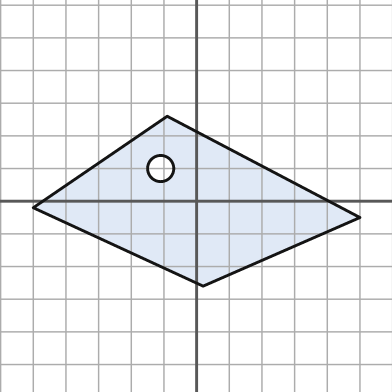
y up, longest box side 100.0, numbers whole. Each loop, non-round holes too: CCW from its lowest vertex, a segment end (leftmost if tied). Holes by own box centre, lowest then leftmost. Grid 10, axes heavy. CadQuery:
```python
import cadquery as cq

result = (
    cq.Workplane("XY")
    .moveTo(2.0, -26.0)
    .lineTo(50.0, -5.0)
    .lineTo(-9.0, 26.0)
    .lineTo(-50.0, -2.0)
    .close()
    .moveTo(-11.0, 10.0)
    .circle(4.0)
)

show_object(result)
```